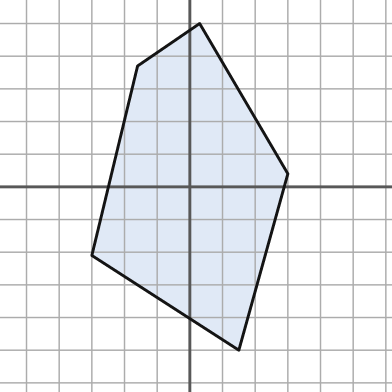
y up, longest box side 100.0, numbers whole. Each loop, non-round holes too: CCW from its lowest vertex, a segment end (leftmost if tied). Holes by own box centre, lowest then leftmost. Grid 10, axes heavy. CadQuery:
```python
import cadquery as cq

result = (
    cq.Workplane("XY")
    .moveTo(15.0, -50.0)
    .lineTo(30.0, 4.0)
    .lineTo(3.0, 50.0)
    .lineTo(-16.0, 37.0)
    .lineTo(-30.0, -21.0)
    .close()
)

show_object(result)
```